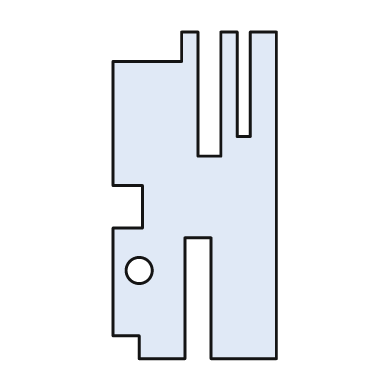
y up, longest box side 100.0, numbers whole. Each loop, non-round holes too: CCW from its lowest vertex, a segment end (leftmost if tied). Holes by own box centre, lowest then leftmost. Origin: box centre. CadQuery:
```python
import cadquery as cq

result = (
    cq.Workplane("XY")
    .moveTo(-17.0, -50.0)
    .lineTo(-3.0, -50.0)
    .lineTo(-3.0, -13.0)
    .lineTo(5.0, -13.0)
    .lineTo(5.0, -50.0)
    .lineTo(25.0, -50.0)
    .lineTo(25.0, 50.0)
    .lineTo(17.0, 50.0)
    .lineTo(17.0, 18.0)
    .lineTo(13.0, 18.0)
    .lineTo(13.0, 50.0)
    .lineTo(8.0, 50.0)
    .lineTo(8.0, 12.0)
    .lineTo(1.0, 12.0)
    .lineTo(1.0, 50.0)
    .lineTo(-4.0, 50.0)
    .lineTo(-4.0, 41.0)
    .lineTo(-25.0, 41.0)
    .lineTo(-25.0, 3.0)
    .lineTo(-16.0, 3.0)
    .lineTo(-16.0, -10.0)
    .lineTo(-25.0, -10.0)
    .lineTo(-25.0, -43.0)
    .lineTo(-17.0, -43.0)
    .close()
    .moveTo(-17.0, -23.0)
    .circle(4.0)
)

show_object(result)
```